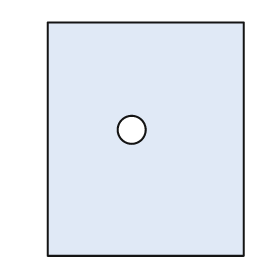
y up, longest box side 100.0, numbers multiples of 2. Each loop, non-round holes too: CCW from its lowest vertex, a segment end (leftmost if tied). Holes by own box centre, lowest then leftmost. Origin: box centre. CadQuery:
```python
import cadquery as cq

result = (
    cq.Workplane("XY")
    .moveTo(-42.0, -50.0)
    .lineTo(42.0, -50.0)
    .lineTo(42.0, 50.0)
    .lineTo(-42.0, 50.0)
    .close()
    .moveTo(-6.0, 4.0)
    .circle(6.0)
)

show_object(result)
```